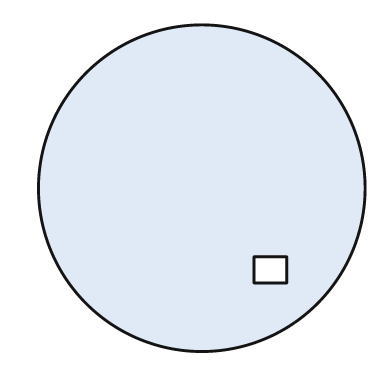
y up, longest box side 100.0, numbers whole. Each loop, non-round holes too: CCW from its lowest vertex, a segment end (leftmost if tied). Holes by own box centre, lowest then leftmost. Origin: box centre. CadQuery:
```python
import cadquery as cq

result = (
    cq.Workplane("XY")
    .moveTo(0.0, 0.0)
    .circle(50.0)
    .moveTo(16.0, -29.0)
    .lineTo(26.0, -29.0)
    .lineTo(26.0, -21.0)
    .lineTo(16.0, -21.0)
    .close()
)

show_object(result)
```